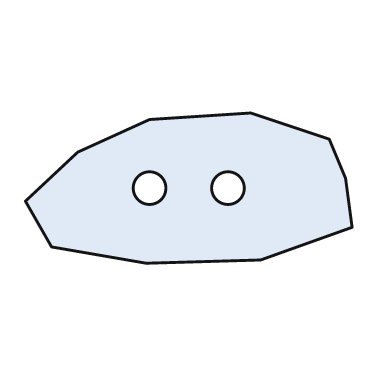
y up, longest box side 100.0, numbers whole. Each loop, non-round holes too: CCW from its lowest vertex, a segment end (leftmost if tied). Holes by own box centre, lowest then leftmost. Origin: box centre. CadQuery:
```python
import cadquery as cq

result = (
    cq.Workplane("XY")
    .moveTo(-13.0, -23.0)
    .lineTo(22.0, -22.0)
    .lineTo(50.0, -12.0)
    .lineTo(48.0, 3.0)
    .lineTo(43.0, 15.0)
    .lineTo(19.0, 23.0)
    .lineTo(-12.0, 21.0)
    .lineTo(-34.0, 11.0)
    .lineTo(-50.0, -4.0)
    .lineTo(-42.0, -18.0)
    .close()
    .moveTo(-12.0, 0.0)
    .circle(5.0)
    .moveTo(12.0, 0.0)
    .circle(5.0)
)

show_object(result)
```